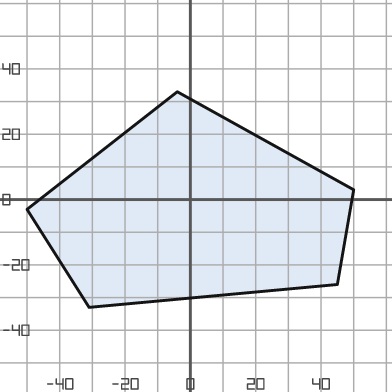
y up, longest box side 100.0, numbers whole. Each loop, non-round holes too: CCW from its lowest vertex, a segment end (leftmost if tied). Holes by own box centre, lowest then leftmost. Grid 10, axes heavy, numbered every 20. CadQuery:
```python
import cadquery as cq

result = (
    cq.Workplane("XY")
    .moveTo(-31.0, -33.0)
    .lineTo(45.0, -26.0)
    .lineTo(50.0, 3.0)
    .lineTo(-4.0, 33.0)
    .lineTo(-50.0, -3.0)
    .close()
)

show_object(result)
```